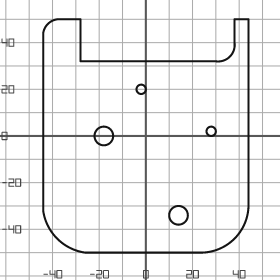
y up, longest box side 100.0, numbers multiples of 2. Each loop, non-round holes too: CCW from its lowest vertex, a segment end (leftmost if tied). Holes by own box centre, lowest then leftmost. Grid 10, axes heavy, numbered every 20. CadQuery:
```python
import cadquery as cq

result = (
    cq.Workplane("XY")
    .moveTo(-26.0, -50.0)
    .lineTo(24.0, -50.0)
    .threePointArc((38.0, -44.0), (44.0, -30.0))
    .lineTo(44.0, 50.0)
    .lineTo(38.0, 50.0)
    .lineTo(38.0, 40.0)
    .threePointArc((36.0, 34.0), (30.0, 32.0))
    .lineTo(-28.0, 32.0)
    .lineTo(-28.0, 50.0)
    .lineTo(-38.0, 50.0)
    .threePointArc((-42.0, 48.0), (-44.0, 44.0))
    .lineTo(-44.0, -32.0)
    .threePointArc((-38.0, -44.0), (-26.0, -50.0))
    .close()
    .moveTo(14.0, -34.0)
    .circle(4.0)
    .moveTo(-18.0, 0.0)
    .circle(4.0)
    .moveTo(28.0, 2.0)
    .circle(2.0)
    .moveTo(-2.0, 20.0)
    .circle(2.0)
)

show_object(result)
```